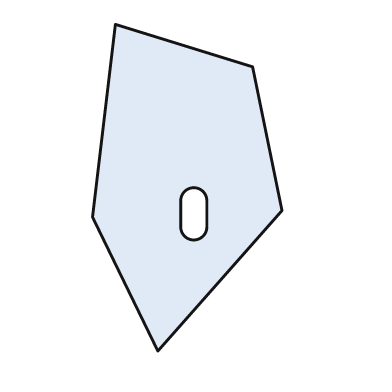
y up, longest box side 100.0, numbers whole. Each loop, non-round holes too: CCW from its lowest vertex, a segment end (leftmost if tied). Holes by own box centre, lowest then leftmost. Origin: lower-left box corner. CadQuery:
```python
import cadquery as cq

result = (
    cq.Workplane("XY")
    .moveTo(20.0, 0.0)
    .lineTo(58.0, 43.0)
    .lineTo(49.0, 87.0)
    .lineTo(7.0, 100.0)
    .lineTo(0.0, 41.0)
    .close()
    .moveTo(27.0, 38.0)
    .threePointArc((31.0, 34.0), (35.0, 38.0))
    .lineTo(35.0, 46.0)
    .threePointArc((31.0, 50.0), (27.0, 46.0))
    .close()
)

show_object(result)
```